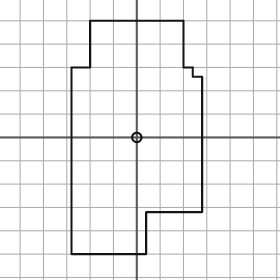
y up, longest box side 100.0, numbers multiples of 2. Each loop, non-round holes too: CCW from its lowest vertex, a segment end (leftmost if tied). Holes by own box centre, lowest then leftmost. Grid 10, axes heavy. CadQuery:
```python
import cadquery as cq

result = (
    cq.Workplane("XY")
    .moveTo(-28.0, -50.0)
    .lineTo(4.0, -50.0)
    .lineTo(4.0, -32.0)
    .lineTo(28.0, -32.0)
    .lineTo(28.0, 26.0)
    .lineTo(24.0, 26.0)
    .lineTo(24.0, 30.0)
    .lineTo(20.0, 30.0)
    .lineTo(20.0, 50.0)
    .lineTo(-20.0, 50.0)
    .lineTo(-20.0, 30.0)
    .lineTo(-28.0, 30.0)
    .close()
    .moveTo(0.0, 0.0)
    .circle(2.0)
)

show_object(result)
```